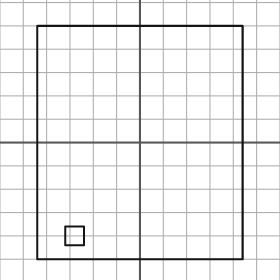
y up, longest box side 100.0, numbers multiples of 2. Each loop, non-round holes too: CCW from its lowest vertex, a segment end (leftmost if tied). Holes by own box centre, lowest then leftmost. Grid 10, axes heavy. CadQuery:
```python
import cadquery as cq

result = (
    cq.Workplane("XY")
    .moveTo(-44.0, -50.0)
    .lineTo(44.0, -50.0)
    .lineTo(44.0, 50.0)
    .lineTo(-44.0, 50.0)
    .close()
    .moveTo(-32.0, -44.0)
    .lineTo(-24.0, -44.0)
    .lineTo(-24.0, -36.0)
    .lineTo(-32.0, -36.0)
    .close()
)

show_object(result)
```